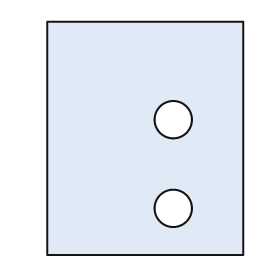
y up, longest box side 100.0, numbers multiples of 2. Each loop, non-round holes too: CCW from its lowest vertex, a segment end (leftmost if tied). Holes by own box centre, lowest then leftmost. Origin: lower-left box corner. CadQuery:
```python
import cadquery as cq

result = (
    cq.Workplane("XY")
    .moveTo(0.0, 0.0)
    .lineTo(84.0, 0.0)
    .lineTo(84.0, 100.0)
    .lineTo(0.0, 100.0)
    .close()
    .moveTo(54.0, 20.0)
    .circle(8.0)
    .moveTo(54.0, 58.0)
    .circle(8.0)
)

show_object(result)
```